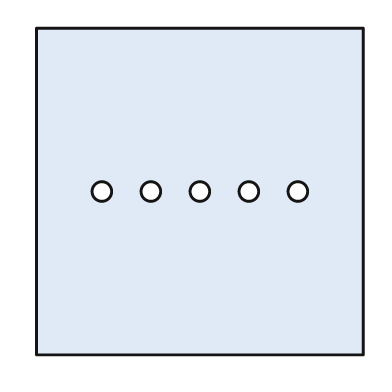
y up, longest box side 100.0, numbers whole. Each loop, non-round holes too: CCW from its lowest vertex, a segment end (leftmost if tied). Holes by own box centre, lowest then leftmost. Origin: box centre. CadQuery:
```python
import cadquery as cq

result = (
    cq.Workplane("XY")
    .moveTo(-50.0, -50.0)
    .lineTo(50.0, -50.0)
    .lineTo(50.0, 50.0)
    .lineTo(-50.0, 50.0)
    .close()
    .moveTo(-30.0, 0.0)
    .circle(3.0)
    .moveTo(-15.0, 0.0)
    .circle(3.0)
    .moveTo(0.0, 0.0)
    .circle(3.0)
    .moveTo(15.0, 0.0)
    .circle(3.0)
    .moveTo(30.0, 0.0)
    .circle(3.0)
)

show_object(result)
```